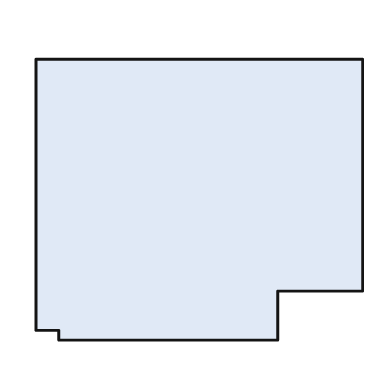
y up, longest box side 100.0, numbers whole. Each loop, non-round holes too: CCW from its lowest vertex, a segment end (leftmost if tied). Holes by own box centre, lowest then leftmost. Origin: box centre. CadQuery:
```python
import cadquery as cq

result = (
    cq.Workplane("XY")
    .moveTo(-43.0, -43.0)
    .lineTo(24.0, -43.0)
    .lineTo(24.0, -28.0)
    .lineTo(50.0, -28.0)
    .lineTo(50.0, 43.0)
    .lineTo(-50.0, 43.0)
    .lineTo(-50.0, -40.0)
    .lineTo(-43.0, -40.0)
    .close()
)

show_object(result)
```